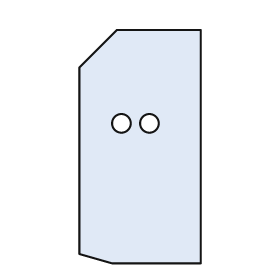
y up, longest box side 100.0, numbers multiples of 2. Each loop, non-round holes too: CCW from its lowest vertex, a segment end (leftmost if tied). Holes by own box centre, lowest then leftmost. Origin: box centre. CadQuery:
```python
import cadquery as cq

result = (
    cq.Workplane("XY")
    .moveTo(-12.0, -50.0)
    .lineTo(26.0, -50.0)
    .lineTo(26.0, 50.0)
    .lineTo(-10.0, 50.0)
    .lineTo(-26.0, 34.0)
    .lineTo(-26.0, -46.0)
    .close()
    .moveTo(-8.0, 10.0)
    .circle(4.0)
    .moveTo(4.0, 10.0)
    .circle(4.0)
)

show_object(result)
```